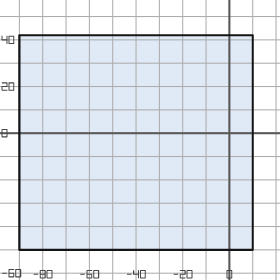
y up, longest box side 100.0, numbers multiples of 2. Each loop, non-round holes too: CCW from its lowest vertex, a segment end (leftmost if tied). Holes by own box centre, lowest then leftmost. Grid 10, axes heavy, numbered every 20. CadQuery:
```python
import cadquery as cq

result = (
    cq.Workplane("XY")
    .moveTo(-90.0, -50.0)
    .lineTo(10.0, -50.0)
    .lineTo(10.0, 42.0)
    .lineTo(-90.0, 42.0)
    .close()
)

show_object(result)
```